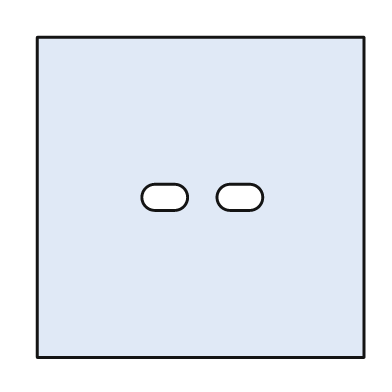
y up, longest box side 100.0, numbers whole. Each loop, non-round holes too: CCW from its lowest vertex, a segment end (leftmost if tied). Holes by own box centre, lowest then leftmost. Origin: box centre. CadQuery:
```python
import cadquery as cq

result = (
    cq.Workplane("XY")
    .moveTo(-50.0, -49.0)
    .lineTo(50.0, -49.0)
    .lineTo(50.0, 49.0)
    .lineTo(-50.0, 49.0)
    .close()
    .moveTo(-14.0, -4.0)
    .lineTo(-8.0, -4.0)
    .threePointArc((-4.0, 0.0), (-8.0, 4.0))
    .lineTo(-14.0, 4.0)
    .threePointArc((-18.0, 0.0), (-14.0, -4.0))
    .close()
    .moveTo(9.0, -4.0)
    .lineTo(15.0, -4.0)
    .threePointArc((19.0, 0.0), (15.0, 4.0))
    .lineTo(9.0, 4.0)
    .threePointArc((5.0, 0.0), (9.0, -4.0))
    .close()
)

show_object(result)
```